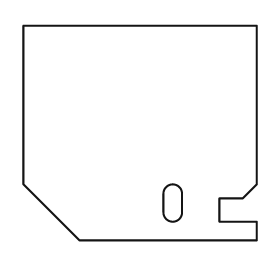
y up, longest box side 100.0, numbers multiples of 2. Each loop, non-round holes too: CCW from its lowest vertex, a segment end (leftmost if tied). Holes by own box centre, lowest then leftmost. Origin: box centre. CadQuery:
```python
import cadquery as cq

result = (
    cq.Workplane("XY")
    .moveTo(-26.0, -46.0)
    .lineTo(50.0, -46.0)
    .lineTo(50.0, -38.0)
    .lineTo(34.0, -38.0)
    .lineTo(34.0, -28.0)
    .lineTo(44.0, -28.0)
    .lineTo(50.0, -22.0)
    .lineTo(50.0, 46.0)
    .lineTo(-50.0, 46.0)
    .lineTo(-50.0, -22.0)
    .close()
    .moveTo(10.0, -34.0)
    .threePointArc((14.0, -38.0), (18.0, -34.0))
    .lineTo(18.0, -26.0)
    .threePointArc((14.0, -22.0), (10.0, -26.0))
    .close()
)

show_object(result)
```